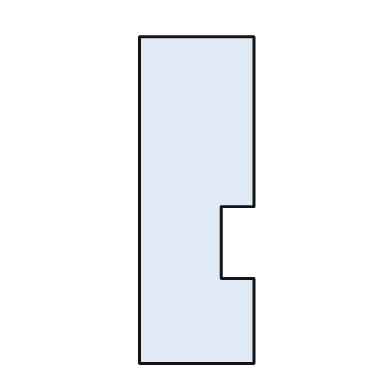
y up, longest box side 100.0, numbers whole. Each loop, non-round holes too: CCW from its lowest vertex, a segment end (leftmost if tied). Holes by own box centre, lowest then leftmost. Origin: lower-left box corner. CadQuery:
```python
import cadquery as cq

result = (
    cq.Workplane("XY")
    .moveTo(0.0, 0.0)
    .lineTo(35.0, 0.0)
    .lineTo(35.0, 26.0)
    .lineTo(25.0, 26.0)
    .lineTo(25.0, 48.0)
    .lineTo(35.0, 48.0)
    .lineTo(35.0, 100.0)
    .lineTo(0.0, 100.0)
    .close()
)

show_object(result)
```